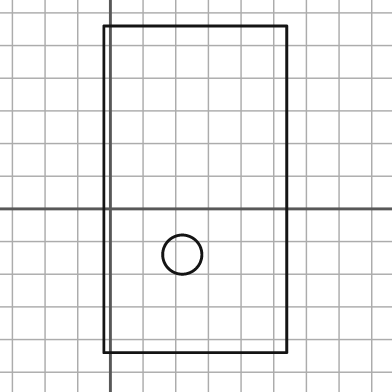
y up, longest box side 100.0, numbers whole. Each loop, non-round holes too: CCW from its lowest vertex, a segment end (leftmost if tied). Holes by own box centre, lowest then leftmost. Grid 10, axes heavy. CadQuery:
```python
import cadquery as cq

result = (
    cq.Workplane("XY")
    .moveTo(-2.0, -44.0)
    .lineTo(54.0, -44.0)
    .lineTo(54.0, 56.0)
    .lineTo(-2.0, 56.0)
    .close()
    .moveTo(22.0, -14.0)
    .circle(6.0)
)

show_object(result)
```